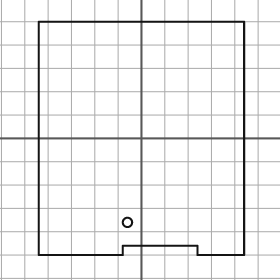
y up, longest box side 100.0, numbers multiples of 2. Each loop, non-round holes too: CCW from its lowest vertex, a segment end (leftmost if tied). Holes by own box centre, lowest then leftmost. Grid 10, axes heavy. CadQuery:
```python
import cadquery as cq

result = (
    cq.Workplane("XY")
    .moveTo(-44.0, -50.0)
    .lineTo(-8.0, -50.0)
    .lineTo(-8.0, -46.0)
    .lineTo(24.0, -46.0)
    .lineTo(24.0, -50.0)
    .lineTo(44.0, -50.0)
    .lineTo(44.0, 50.0)
    .lineTo(-44.0, 50.0)
    .close()
    .moveTo(-6.0, -36.0)
    .circle(2.0)
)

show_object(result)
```